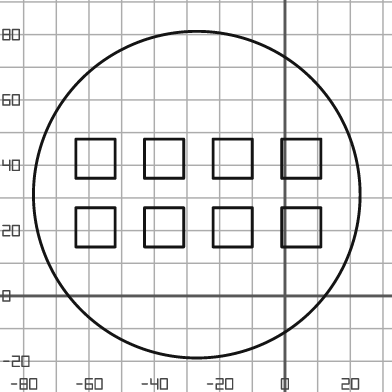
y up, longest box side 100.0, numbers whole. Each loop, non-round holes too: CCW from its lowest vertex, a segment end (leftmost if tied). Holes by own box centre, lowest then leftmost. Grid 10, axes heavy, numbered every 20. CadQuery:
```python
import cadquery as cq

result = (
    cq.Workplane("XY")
    .moveTo(-27.0, 31.0)
    .circle(50.0)
    .moveTo(-64.0, 15.0)
    .lineTo(-52.0, 15.0)
    .lineTo(-52.0, 27.0)
    .lineTo(-64.0, 27.0)
    .close()
    .moveTo(-43.0, 15.0)
    .lineTo(-31.0, 15.0)
    .lineTo(-31.0, 27.0)
    .lineTo(-43.0, 27.0)
    .close()
    .moveTo(-22.0, 15.0)
    .lineTo(-10.0, 15.0)
    .lineTo(-10.0, 27.0)
    .lineTo(-22.0, 27.0)
    .close()
    .moveTo(-1.0, 15.0)
    .lineTo(11.0, 15.0)
    .lineTo(11.0, 27.0)
    .lineTo(-1.0, 27.0)
    .close()
    .moveTo(-64.0, 36.0)
    .lineTo(-52.0, 36.0)
    .lineTo(-52.0, 48.0)
    .lineTo(-64.0, 48.0)
    .close()
    .moveTo(-43.0, 36.0)
    .lineTo(-31.0, 36.0)
    .lineTo(-31.0, 48.0)
    .lineTo(-43.0, 48.0)
    .close()
    .moveTo(-22.0, 36.0)
    .lineTo(-10.0, 36.0)
    .lineTo(-10.0, 48.0)
    .lineTo(-22.0, 48.0)
    .close()
    .moveTo(-1.0, 36.0)
    .lineTo(11.0, 36.0)
    .lineTo(11.0, 48.0)
    .lineTo(-1.0, 48.0)
    .close()
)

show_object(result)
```